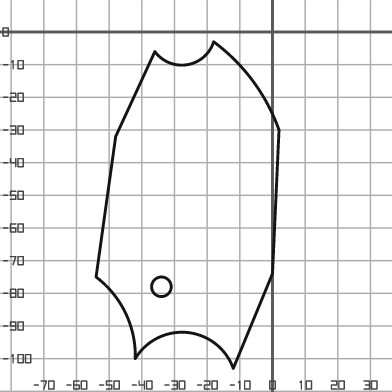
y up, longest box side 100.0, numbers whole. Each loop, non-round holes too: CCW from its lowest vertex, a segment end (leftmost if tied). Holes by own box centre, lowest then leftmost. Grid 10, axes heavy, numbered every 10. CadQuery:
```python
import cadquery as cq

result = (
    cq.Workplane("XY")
    .moveTo(-12.0, -103.0)
    .lineTo(0.0, -74.0)
    .lineTo(2.0, -30.0)
    .threePointArc((-6.0, -15.0), (-18.0, -3.0))
    .threePointArc((-26.0, -10.0), (-36.0, -6.0))
    .lineTo(-48.0, -32.0)
    .lineTo(-54.0, -75.0)
    .threePointArc((-45.0, -86.0), (-42.0, -100.0))
    .threePointArc((-26.0, -92.0), (-12.0, -103.0))
    .close()
    .moveTo(-34.0, -78.0)
    .circle(3.0)
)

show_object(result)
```